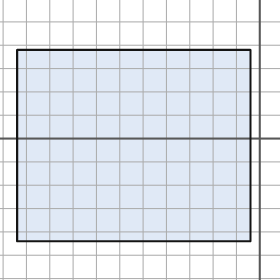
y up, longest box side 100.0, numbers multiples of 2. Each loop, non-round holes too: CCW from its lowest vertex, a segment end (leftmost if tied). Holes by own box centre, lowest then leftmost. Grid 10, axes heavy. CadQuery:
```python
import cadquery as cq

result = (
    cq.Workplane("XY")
    .moveTo(-104.0, -44.0)
    .lineTo(-4.0, -44.0)
    .lineTo(-4.0, 38.0)
    .lineTo(-104.0, 38.0)
    .close()
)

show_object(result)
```